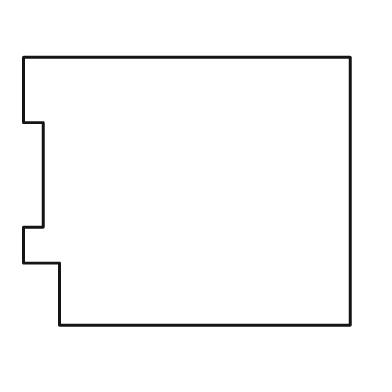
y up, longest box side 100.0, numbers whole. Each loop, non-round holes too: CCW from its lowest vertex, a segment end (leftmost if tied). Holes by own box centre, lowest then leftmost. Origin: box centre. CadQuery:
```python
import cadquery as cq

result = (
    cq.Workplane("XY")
    .moveTo(-39.0, -41.0)
    .lineTo(50.0, -41.0)
    .lineTo(50.0, 41.0)
    .lineTo(-50.0, 41.0)
    .lineTo(-50.0, 21.0)
    .lineTo(-44.0, 21.0)
    .lineTo(-44.0, -11.0)
    .lineTo(-50.0, -11.0)
    .lineTo(-50.0, -22.0)
    .lineTo(-39.0, -22.0)
    .close()
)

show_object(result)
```